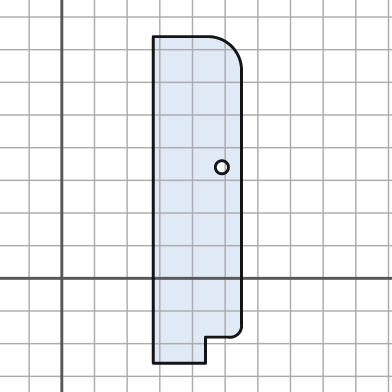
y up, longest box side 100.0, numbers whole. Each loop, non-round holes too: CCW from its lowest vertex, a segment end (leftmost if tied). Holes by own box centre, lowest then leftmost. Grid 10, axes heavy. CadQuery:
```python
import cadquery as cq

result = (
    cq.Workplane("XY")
    .moveTo(28.0, -26.0)
    .lineTo(44.0, -26.0)
    .lineTo(44.0, -18.0)
    .lineTo(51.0, -18.0)
    .threePointArc((54.0, -17.0), (55.0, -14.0))
    .lineTo(55.0, 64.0)
    .threePointArc((52.0, 71.0), (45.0, 74.0))
    .lineTo(28.0, 74.0)
    .close()
    .moveTo(49.0, 34.0)
    .circle(2.0)
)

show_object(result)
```